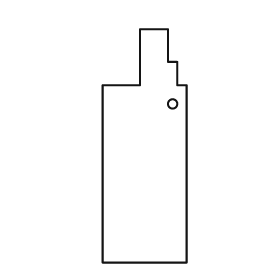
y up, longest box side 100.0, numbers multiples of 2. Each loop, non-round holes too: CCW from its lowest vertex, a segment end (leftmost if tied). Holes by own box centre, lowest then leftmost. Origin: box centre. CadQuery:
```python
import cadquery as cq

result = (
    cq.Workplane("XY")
    .moveTo(-18.0, -50.0)
    .lineTo(18.0, -50.0)
    .lineTo(18.0, 26.0)
    .lineTo(14.0, 26.0)
    .lineTo(14.0, 36.0)
    .lineTo(10.0, 36.0)
    .lineTo(10.0, 50.0)
    .lineTo(-2.0, 50.0)
    .lineTo(-2.0, 26.0)
    .lineTo(-18.0, 26.0)
    .close()
    .moveTo(12.0, 18.0)
    .circle(2.0)
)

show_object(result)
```